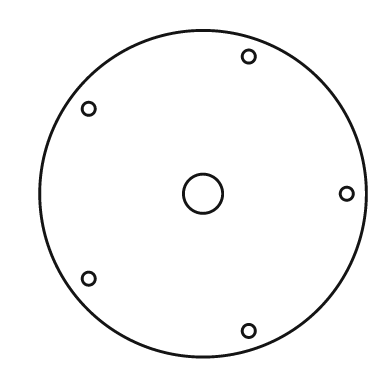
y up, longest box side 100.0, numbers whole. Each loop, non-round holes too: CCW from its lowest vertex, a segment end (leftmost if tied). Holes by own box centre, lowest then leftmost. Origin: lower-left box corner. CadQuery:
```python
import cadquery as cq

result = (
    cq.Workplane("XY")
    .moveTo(50.0, 50.0)
    .circle(50.0)
    .moveTo(64.0, 8.0)
    .circle(2.0)
    .moveTo(15.0, 24.0)
    .circle(2.0)
    .moveTo(50.0, 50.0)
    .circle(6.0)
    .moveTo(94.0, 50.0)
    .circle(2.0)
    .moveTo(15.0, 76.0)
    .circle(2.0)
    .moveTo(64.0, 92.0)
    .circle(2.0)
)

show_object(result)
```